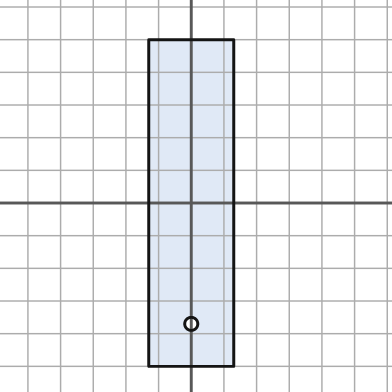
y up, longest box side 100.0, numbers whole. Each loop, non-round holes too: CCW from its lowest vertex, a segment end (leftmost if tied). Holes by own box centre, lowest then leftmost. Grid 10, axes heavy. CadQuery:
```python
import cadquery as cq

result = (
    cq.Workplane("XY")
    .moveTo(-13.0, -50.0)
    .lineTo(13.0, -50.0)
    .lineTo(13.0, 50.0)
    .lineTo(-13.0, 50.0)
    .close()
    .moveTo(0.0, -37.0)
    .circle(2.0)
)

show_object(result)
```